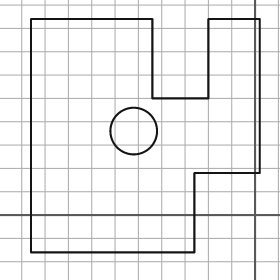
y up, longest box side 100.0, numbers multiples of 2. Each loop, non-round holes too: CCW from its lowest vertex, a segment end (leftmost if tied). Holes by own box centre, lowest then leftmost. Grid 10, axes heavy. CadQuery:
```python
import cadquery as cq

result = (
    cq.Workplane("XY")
    .moveTo(-96.0, -16.0)
    .lineTo(-26.0, -16.0)
    .lineTo(-26.0, 18.0)
    .lineTo(2.0, 18.0)
    .lineTo(2.0, 84.0)
    .lineTo(-20.0, 84.0)
    .lineTo(-20.0, 50.0)
    .lineTo(-44.0, 50.0)
    .lineTo(-44.0, 84.0)
    .lineTo(-96.0, 84.0)
    .close()
    .moveTo(-52.0, 36.0)
    .circle(10.0)
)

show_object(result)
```